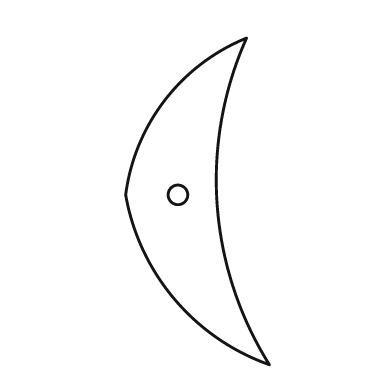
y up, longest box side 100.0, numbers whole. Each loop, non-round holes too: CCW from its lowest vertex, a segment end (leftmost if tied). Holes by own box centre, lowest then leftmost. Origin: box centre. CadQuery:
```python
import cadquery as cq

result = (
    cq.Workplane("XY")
    .moveTo(22.0, -50.0)
    .threePointArc((6.0, -1.0), (15.0, 50.0))
    .threePointArc((-10.0, 31.0), (-22.0, 2.0))
    .threePointArc((-7.0, -30.0), (22.0, -50.0))
    .close()
    .moveTo(-6.0, 2.0)
    .circle(3.0)
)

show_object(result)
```